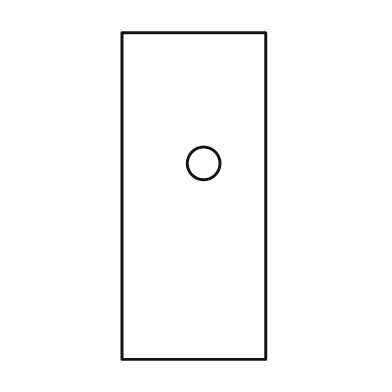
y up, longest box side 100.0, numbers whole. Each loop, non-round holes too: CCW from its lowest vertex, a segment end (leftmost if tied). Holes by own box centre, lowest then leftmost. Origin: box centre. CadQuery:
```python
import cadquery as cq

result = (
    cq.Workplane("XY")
    .moveTo(-22.0, -50.0)
    .lineTo(22.0, -50.0)
    .lineTo(22.0, 50.0)
    .lineTo(-22.0, 50.0)
    .close()
    .moveTo(3.0, 10.0)
    .circle(5.0)
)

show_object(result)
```